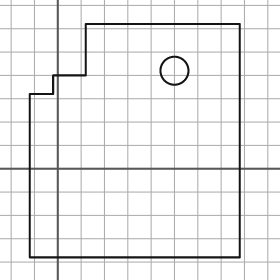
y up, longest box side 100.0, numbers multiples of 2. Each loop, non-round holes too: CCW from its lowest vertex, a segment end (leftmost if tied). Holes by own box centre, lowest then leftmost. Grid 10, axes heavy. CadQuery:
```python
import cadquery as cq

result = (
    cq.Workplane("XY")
    .moveTo(-12.0, -38.0)
    .lineTo(78.0, -38.0)
    .lineTo(78.0, 62.0)
    .lineTo(12.0, 62.0)
    .lineTo(12.0, 40.0)
    .lineTo(-2.0, 40.0)
    .lineTo(-2.0, 32.0)
    .lineTo(-12.0, 32.0)
    .close()
    .moveTo(50.0, 42.0)
    .circle(6.0)
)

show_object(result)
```